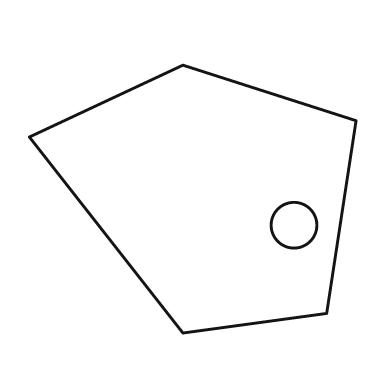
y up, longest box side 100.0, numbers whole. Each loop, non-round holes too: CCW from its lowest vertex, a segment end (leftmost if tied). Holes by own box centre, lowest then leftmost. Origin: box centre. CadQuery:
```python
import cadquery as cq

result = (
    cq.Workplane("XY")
    .moveTo(-3.0, -41.0)
    .lineTo(41.0, -35.0)
    .lineTo(50.0, 24.0)
    .lineTo(-3.0, 41.0)
    .lineTo(-50.0, 19.0)
    .close()
    .moveTo(31.0, -8.0)
    .circle(7.0)
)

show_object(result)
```